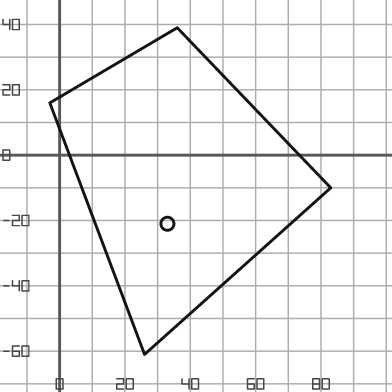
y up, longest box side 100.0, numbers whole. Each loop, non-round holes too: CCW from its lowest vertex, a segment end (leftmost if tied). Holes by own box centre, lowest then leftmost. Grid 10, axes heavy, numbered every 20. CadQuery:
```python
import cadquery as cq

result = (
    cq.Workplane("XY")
    .moveTo(26.0, -61.0)
    .lineTo(83.0, -10.0)
    .lineTo(36.0, 39.0)
    .lineTo(-3.0, 16.0)
    .close()
    .moveTo(33.0, -21.0)
    .circle(2.0)
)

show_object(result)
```